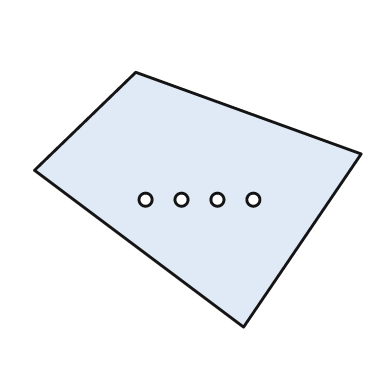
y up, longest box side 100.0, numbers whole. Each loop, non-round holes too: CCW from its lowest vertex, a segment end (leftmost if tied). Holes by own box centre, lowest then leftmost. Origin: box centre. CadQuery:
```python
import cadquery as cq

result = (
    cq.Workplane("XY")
    .moveTo(14.0, -39.0)
    .lineTo(50.0, 14.0)
    .lineTo(-19.0, 39.0)
    .lineTo(-50.0, 9.0)
    .close()
    .moveTo(-16.0, 0.0)
    .circle(2.0)
    .moveTo(-5.0, 0.0)
    .circle(2.0)
    .moveTo(6.0, 0.0)
    .circle(2.0)
    .moveTo(17.0, 0.0)
    .circle(2.0)
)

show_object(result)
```